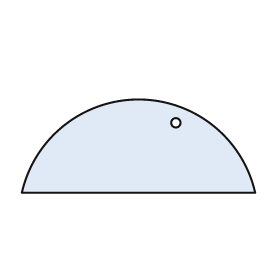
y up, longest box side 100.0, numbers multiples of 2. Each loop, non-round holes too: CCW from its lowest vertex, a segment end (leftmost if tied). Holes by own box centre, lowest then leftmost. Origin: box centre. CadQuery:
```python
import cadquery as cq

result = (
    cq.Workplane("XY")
    .moveTo(-50.0, -20.0)
    .lineTo(50.0, -20.0)
    .threePointArc((0.0, 20.0), (-50.0, -20.0))
    .close()
    .moveTo(16.0, 10.0)
    .circle(2.0)
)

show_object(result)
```